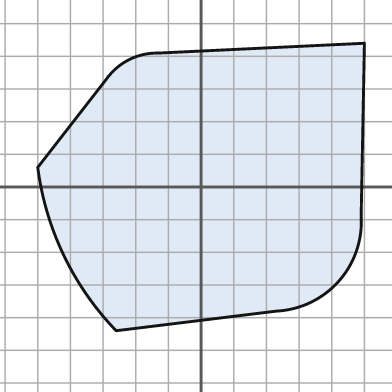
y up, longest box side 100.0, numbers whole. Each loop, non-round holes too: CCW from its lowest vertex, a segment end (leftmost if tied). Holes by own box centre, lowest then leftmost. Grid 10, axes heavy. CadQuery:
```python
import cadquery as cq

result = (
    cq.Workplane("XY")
    .moveTo(-26.0, -44.0)
    .lineTo(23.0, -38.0)
    .threePointArc((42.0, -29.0), (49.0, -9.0))
    .lineTo(50.0, 44.0)
    .lineTo(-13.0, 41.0)
    .threePointArc((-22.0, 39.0), (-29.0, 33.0))
    .lineTo(-50.0, 6.0)
    .threePointArc((-42.0, -21.0), (-26.0, -44.0))
    .close()
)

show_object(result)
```